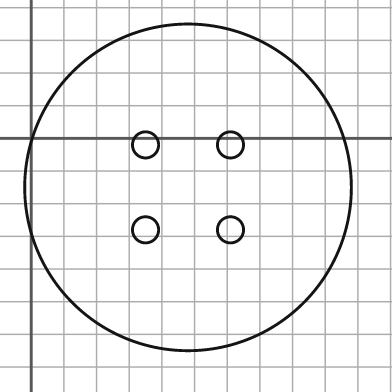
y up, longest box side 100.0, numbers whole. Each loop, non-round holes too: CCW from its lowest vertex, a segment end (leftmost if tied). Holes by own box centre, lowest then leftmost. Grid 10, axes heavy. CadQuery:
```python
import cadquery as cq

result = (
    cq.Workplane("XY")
    .moveTo(48.0, -15.0)
    .circle(50.0)
    .moveTo(35.0, -28.0)
    .circle(4.0)
    .moveTo(61.0, -28.0)
    .circle(4.0)
    .moveTo(35.0, -2.0)
    .circle(4.0)
    .moveTo(61.0, -2.0)
    .circle(4.0)
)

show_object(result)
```